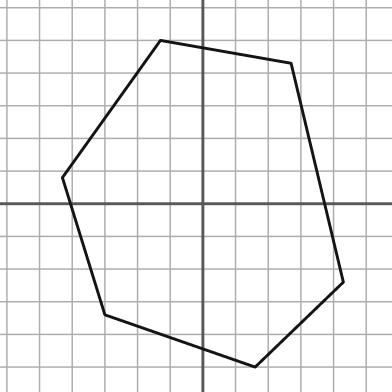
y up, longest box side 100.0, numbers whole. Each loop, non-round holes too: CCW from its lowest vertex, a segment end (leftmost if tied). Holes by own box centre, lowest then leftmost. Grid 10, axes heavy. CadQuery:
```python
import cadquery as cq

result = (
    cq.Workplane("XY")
    .moveTo(16.0, -50.0)
    .lineTo(43.0, -24.0)
    .lineTo(27.0, 43.0)
    .lineTo(-13.0, 50.0)
    .lineTo(-43.0, 8.0)
    .lineTo(-30.0, -34.0)
    .close()
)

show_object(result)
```